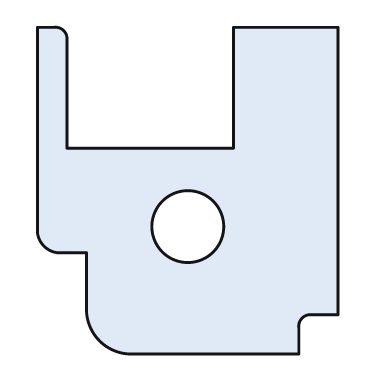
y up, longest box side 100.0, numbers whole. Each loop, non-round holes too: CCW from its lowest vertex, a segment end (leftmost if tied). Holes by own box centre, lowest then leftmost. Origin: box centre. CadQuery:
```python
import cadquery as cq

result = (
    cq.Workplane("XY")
    .moveTo(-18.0, -50.0)
    .lineTo(34.0, -50.0)
    .lineTo(34.0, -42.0)
    .threePointArc((35.0, -39.0), (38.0, -38.0))
    .lineTo(46.0, -38.0)
    .lineTo(46.0, 50.0)
    .lineTo(14.0, 50.0)
    .lineTo(14.0, 13.0)
    .lineTo(-37.0, 13.0)
    .lineTo(-37.0, 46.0)
    .threePointArc((-38.0, 49.0), (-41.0, 50.0))
    .lineTo(-46.0, 50.0)
    .lineTo(-46.0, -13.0)
    .threePointArc((-44.0, -17.0), (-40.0, -19.0))
    .lineTo(-31.0, -19.0)
    .lineTo(-31.0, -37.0)
    .threePointArc((-27.0, -46.0), (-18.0, -50.0))
    .close()
    .moveTo(0.0, -11.0)
    .circle(11.0)
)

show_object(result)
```